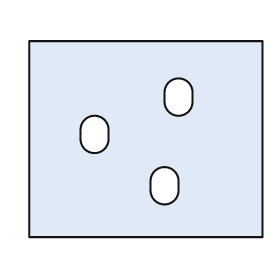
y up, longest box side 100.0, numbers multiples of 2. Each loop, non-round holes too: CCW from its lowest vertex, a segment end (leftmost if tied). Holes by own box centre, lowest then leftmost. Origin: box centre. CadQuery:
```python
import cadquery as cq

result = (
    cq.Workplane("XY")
    .moveTo(-50.0, -42.0)
    .lineTo(50.0, -42.0)
    .lineTo(50.0, 42.0)
    .lineTo(-50.0, 42.0)
    .close()
    .moveTo(2.0, -22.0)
    .threePointArc((8.0, -28.0), (14.0, -22.0))
    .lineTo(14.0, -18.0)
    .threePointArc((8.0, -12.0), (2.0, -18.0))
    .close()
    .moveTo(-28.0, 0.0)
    .threePointArc((-22.0, -6.0), (-16.0, 0.0))
    .lineTo(-16.0, 4.0)
    .threePointArc((-22.0, 10.0), (-28.0, 4.0))
    .close()
    .moveTo(8.0, 16.0)
    .threePointArc((14.0, 10.0), (20.0, 16.0))
    .lineTo(20.0, 20.0)
    .threePointArc((14.0, 26.0), (8.0, 20.0))
    .close()
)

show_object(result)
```